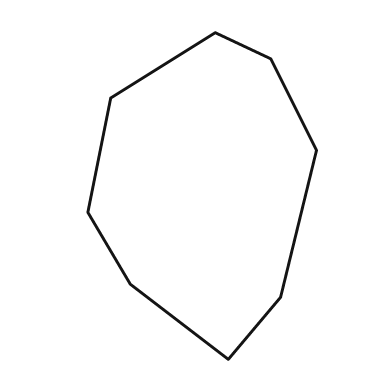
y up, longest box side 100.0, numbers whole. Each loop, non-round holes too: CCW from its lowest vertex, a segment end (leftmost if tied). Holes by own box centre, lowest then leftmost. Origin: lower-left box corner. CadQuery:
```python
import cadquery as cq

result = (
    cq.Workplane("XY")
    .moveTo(43.0, 0.0)
    .lineTo(59.0, 19.0)
    .lineTo(70.0, 64.0)
    .lineTo(56.0, 92.0)
    .lineTo(39.0, 100.0)
    .lineTo(7.0, 80.0)
    .lineTo(0.0, 45.0)
    .lineTo(13.0, 23.0)
    .close()
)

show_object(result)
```